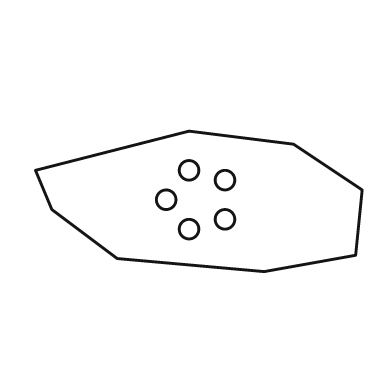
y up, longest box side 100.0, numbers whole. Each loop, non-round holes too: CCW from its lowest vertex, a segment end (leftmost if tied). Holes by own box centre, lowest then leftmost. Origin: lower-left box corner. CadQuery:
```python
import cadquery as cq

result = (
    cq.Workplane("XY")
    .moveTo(70.0, 0.0)
    .lineTo(98.0, 5.0)
    .lineTo(100.0, 25.0)
    .lineTo(79.0, 39.0)
    .lineTo(47.0, 43.0)
    .lineTo(0.0, 31.0)
    .lineTo(5.0, 19.0)
    .lineTo(25.0, 4.0)
    .close()
    .moveTo(47.0, 13.0)
    .circle(3.0)
    .moveTo(58.0, 16.0)
    .circle(3.0)
    .moveTo(40.0, 22.0)
    .circle(3.0)
    .moveTo(58.0, 28.0)
    .circle(3.0)
    .moveTo(47.0, 31.0)
    .circle(3.0)
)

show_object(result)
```